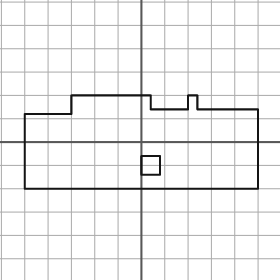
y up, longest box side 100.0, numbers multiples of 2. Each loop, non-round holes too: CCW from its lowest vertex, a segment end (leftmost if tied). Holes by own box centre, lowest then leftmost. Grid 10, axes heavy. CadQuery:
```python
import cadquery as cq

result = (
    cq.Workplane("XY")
    .moveTo(-50.0, -20.0)
    .lineTo(50.0, -20.0)
    .lineTo(50.0, 14.0)
    .lineTo(24.0, 14.0)
    .lineTo(24.0, 20.0)
    .lineTo(20.0, 20.0)
    .lineTo(20.0, 14.0)
    .lineTo(4.0, 14.0)
    .lineTo(4.0, 20.0)
    .lineTo(-30.0, 20.0)
    .lineTo(-30.0, 12.0)
    .lineTo(-50.0, 12.0)
    .close()
    .moveTo(0.0, -14.0)
    .lineTo(8.0, -14.0)
    .lineTo(8.0, -6.0)
    .lineTo(0.0, -6.0)
    .close()
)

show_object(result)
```